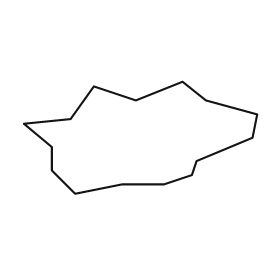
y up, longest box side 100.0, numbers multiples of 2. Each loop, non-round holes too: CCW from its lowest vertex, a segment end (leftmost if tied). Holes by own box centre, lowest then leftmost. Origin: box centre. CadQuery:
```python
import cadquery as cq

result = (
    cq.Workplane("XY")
    .moveTo(-28.0, -24.0)
    .lineTo(-8.0, -20.0)
    .lineTo(10.0, -20.0)
    .lineTo(22.0, -16.0)
    .lineTo(24.0, -10.0)
    .lineTo(48.0, 0.0)
    .lineTo(50.0, 10.0)
    .lineTo(28.0, 16.0)
    .lineTo(18.0, 24.0)
    .lineTo(-2.0, 16.0)
    .lineTo(-20.0, 22.0)
    .lineTo(-30.0, 8.0)
    .lineTo(-50.0, 6.0)
    .lineTo(-38.0, -4.0)
    .lineTo(-38.0, -14.0)
    .close()
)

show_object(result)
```